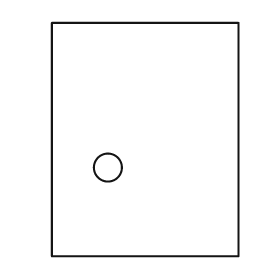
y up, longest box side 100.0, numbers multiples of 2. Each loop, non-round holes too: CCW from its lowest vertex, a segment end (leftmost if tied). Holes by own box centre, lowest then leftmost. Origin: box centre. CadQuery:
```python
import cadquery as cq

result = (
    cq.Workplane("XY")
    .moveTo(-40.0, -50.0)
    .lineTo(40.0, -50.0)
    .lineTo(40.0, 50.0)
    .lineTo(-40.0, 50.0)
    .close()
    .moveTo(-16.0, -12.0)
    .circle(6.0)
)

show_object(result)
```